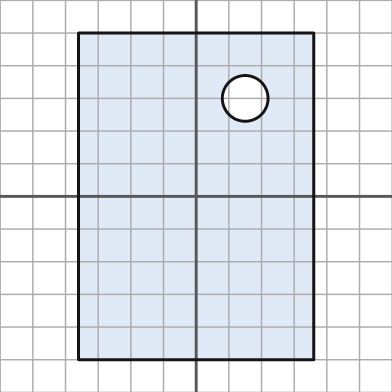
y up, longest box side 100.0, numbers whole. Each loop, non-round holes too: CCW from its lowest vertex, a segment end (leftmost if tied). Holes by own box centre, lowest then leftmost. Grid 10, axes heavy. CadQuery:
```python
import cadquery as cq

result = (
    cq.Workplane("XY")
    .moveTo(-36.0, -50.0)
    .lineTo(36.0, -50.0)
    .lineTo(36.0, 50.0)
    .lineTo(-36.0, 50.0)
    .close()
    .moveTo(15.0, 30.0)
    .circle(7.0)
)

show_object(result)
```